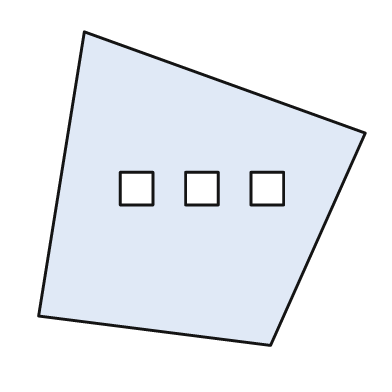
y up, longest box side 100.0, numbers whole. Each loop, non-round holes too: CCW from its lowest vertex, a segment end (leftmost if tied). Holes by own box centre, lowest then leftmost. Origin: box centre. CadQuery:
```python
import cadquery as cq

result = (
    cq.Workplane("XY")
    .moveTo(21.0, -48.0)
    .lineTo(50.0, 17.0)
    .lineTo(-36.0, 48.0)
    .lineTo(-50.0, -39.0)
    .close()
    .moveTo(-25.0, -5.0)
    .lineTo(-15.0, -5.0)
    .lineTo(-15.0, 5.0)
    .lineTo(-25.0, 5.0)
    .close()
    .moveTo(-5.0, -5.0)
    .lineTo(5.0, -5.0)
    .lineTo(5.0, 5.0)
    .lineTo(-5.0, 5.0)
    .close()
    .moveTo(15.0, -5.0)
    .lineTo(25.0, -5.0)
    .lineTo(25.0, 5.0)
    .lineTo(15.0, 5.0)
    .close()
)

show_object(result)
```